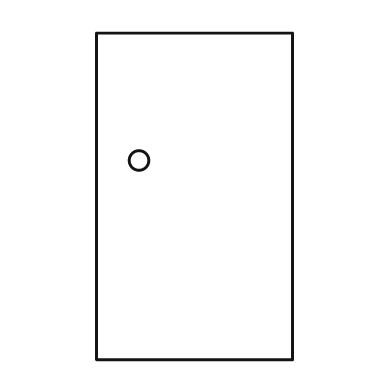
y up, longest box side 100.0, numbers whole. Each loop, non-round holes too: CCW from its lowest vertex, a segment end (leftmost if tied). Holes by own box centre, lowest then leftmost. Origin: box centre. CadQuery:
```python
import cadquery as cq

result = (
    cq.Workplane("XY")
    .moveTo(-30.0, -50.0)
    .lineTo(30.0, -50.0)
    .lineTo(30.0, 50.0)
    .lineTo(-30.0, 50.0)
    .close()
    .moveTo(-17.0, 11.0)
    .circle(3.0)
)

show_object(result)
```